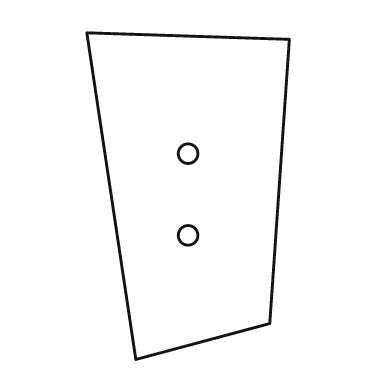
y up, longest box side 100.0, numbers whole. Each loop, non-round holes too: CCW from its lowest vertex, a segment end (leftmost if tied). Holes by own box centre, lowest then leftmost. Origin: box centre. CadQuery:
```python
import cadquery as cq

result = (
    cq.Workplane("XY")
    .moveTo(-16.0, -50.0)
    .lineTo(25.0, -39.0)
    .lineTo(31.0, 48.0)
    .lineTo(-31.0, 50.0)
    .close()
    .moveTo(0.0, -12.0)
    .circle(3.0)
    .moveTo(0.0, 13.0)
    .circle(3.0)
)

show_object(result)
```